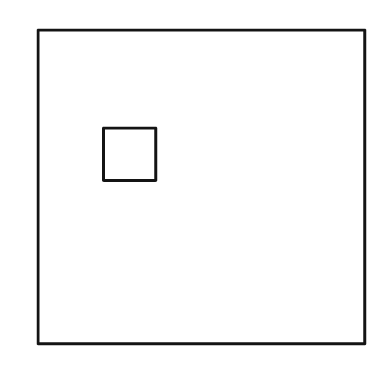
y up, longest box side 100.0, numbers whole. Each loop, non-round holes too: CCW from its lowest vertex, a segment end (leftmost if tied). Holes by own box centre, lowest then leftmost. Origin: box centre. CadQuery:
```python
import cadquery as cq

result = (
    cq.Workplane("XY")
    .moveTo(-50.0, -48.0)
    .lineTo(50.0, -48.0)
    .lineTo(50.0, 48.0)
    .lineTo(-50.0, 48.0)
    .close()
    .moveTo(-30.0, 2.0)
    .lineTo(-14.0, 2.0)
    .lineTo(-14.0, 18.0)
    .lineTo(-30.0, 18.0)
    .close()
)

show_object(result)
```